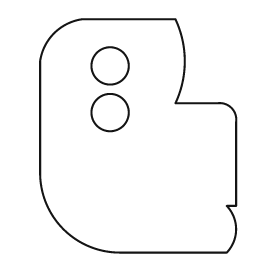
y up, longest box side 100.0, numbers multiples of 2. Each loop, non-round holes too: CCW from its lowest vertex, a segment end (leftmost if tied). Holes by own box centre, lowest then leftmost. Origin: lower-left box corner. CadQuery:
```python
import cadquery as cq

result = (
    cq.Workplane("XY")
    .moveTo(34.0, 0.0)
    .lineTo(80.0, 0.0)
    .threePointArc((84.0, 10.0), (80.0, 20.0))
    .lineTo(84.0, 20.0)
    .lineTo(84.0, 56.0)
    .threePointArc((82.0, 62.0), (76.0, 64.0))
    .lineTo(58.0, 64.0)
    .threePointArc((62.0, 82.0), (58.0, 100.0))
    .lineTo(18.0, 100.0)
    .threePointArc((6.0, 94.0), (0.0, 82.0))
    .lineTo(0.0, 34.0)
    .threePointArc((10.0, 10.0), (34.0, 0.0))
    .close()
    .moveTo(30.0, 60.0)
    .circle(8.0)
    .moveTo(30.0, 80.0)
    .circle(8.0)
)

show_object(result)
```